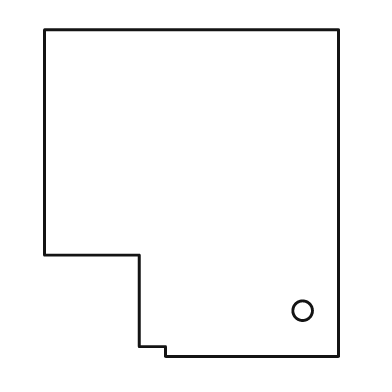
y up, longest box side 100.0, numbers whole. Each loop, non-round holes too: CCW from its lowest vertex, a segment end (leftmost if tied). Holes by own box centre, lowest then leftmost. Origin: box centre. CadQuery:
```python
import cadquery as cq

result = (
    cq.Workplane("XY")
    .moveTo(-8.0, -50.0)
    .lineTo(45.0, -50.0)
    .lineTo(45.0, 50.0)
    .lineTo(-45.0, 50.0)
    .lineTo(-45.0, -19.0)
    .lineTo(-16.0, -19.0)
    .lineTo(-16.0, -47.0)
    .lineTo(-8.0, -47.0)
    .close()
    .moveTo(34.0, -36.0)
    .circle(3.0)
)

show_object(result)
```